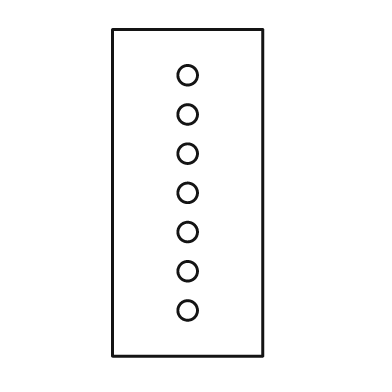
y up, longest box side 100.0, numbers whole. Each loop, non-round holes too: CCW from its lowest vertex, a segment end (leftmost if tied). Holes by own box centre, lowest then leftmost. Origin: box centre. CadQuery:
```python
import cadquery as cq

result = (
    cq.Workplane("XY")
    .moveTo(-23.0, -50.0)
    .lineTo(23.0, -50.0)
    .lineTo(23.0, 50.0)
    .lineTo(-23.0, 50.0)
    .close()
    .moveTo(0.0, -36.0)
    .circle(3.0)
    .moveTo(0.0, -24.0)
    .circle(3.0)
    .moveTo(0.0, -12.0)
    .circle(3.0)
    .moveTo(0.0, 0.0)
    .circle(3.0)
    .moveTo(0.0, 12.0)
    .circle(3.0)
    .moveTo(0.0, 24.0)
    .circle(3.0)
    .moveTo(0.0, 36.0)
    .circle(3.0)
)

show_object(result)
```